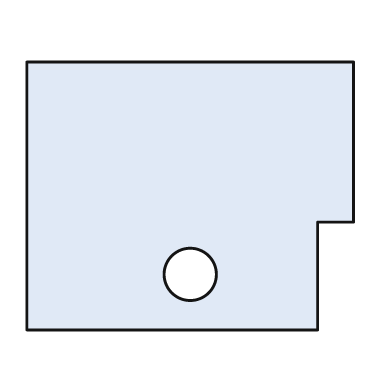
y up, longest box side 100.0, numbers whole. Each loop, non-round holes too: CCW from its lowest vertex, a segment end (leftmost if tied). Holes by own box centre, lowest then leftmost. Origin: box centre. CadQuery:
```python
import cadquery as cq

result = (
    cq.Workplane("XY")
    .moveTo(-50.0, -41.0)
    .lineTo(39.0, -41.0)
    .lineTo(39.0, -8.0)
    .lineTo(50.0, -8.0)
    .lineTo(50.0, 41.0)
    .lineTo(-50.0, 41.0)
    .close()
    .moveTo(0.0, -24.0)
    .circle(8.0)
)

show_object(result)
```